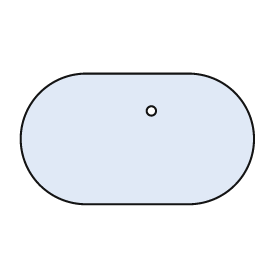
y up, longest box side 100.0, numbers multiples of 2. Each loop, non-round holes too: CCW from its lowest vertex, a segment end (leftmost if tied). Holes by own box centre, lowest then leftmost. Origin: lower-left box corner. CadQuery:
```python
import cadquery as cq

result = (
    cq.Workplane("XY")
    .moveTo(28.0, 0.0)
    .lineTo(72.0, 0.0)
    .threePointArc((100.0, 28.0), (72.0, 56.0))
    .lineTo(28.0, 56.0)
    .threePointArc((0.0, 28.0), (28.0, 0.0))
    .close()
    .moveTo(56.0, 40.0)
    .circle(2.0)
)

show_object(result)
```